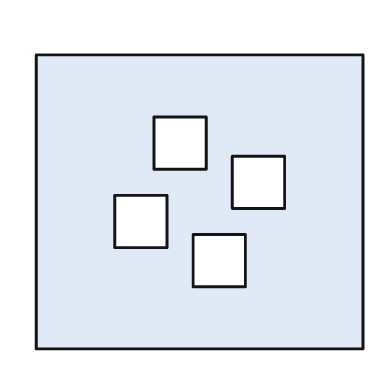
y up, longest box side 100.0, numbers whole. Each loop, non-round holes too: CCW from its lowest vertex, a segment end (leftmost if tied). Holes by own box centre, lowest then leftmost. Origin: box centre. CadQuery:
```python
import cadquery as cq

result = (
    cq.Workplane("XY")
    .moveTo(-50.0, -45.0)
    .lineTo(50.0, -45.0)
    .lineTo(50.0, 45.0)
    .lineTo(-50.0, 45.0)
    .close()
    .moveTo(-2.0, -26.0)
    .lineTo(14.0, -26.0)
    .lineTo(14.0, -10.0)
    .lineTo(-2.0, -10.0)
    .close()
    .moveTo(-26.0, -14.0)
    .lineTo(-10.0, -14.0)
    .lineTo(-10.0, 2.0)
    .lineTo(-26.0, 2.0)
    .close()
    .moveTo(10.0, -2.0)
    .lineTo(26.0, -2.0)
    .lineTo(26.0, 14.0)
    .lineTo(10.0, 14.0)
    .close()
    .moveTo(-14.0, 10.0)
    .lineTo(2.0, 10.0)
    .lineTo(2.0, 26.0)
    .lineTo(-14.0, 26.0)
    .close()
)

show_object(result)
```